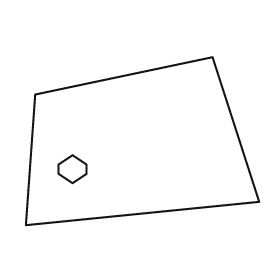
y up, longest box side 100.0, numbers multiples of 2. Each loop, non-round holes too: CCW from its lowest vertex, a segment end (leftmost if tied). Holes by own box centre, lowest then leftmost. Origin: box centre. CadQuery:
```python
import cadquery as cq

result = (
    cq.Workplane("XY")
    .moveTo(-50.0, -36.0)
    .lineTo(50.0, -26.0)
    .lineTo(30.0, 36.0)
    .lineTo(-46.0, 20.0)
    .close()
    .moveTo(-30.0, -18.0)
    .lineTo(-24.0, -14.0)
    .lineTo(-24.0, -10.0)
    .lineTo(-30.0, -6.0)
    .lineTo(-36.0, -10.0)
    .lineTo(-36.0, -14.0)
    .close()
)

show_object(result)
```